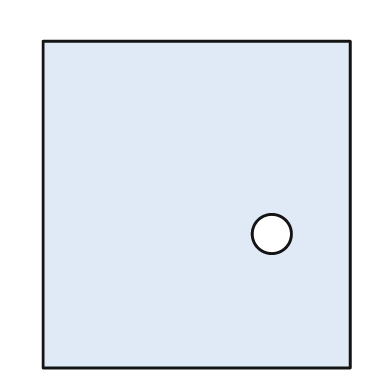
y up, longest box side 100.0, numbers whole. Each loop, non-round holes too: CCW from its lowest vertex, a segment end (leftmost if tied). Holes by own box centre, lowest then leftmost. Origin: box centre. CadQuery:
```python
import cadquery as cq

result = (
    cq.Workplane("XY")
    .moveTo(-47.0, -50.0)
    .lineTo(47.0, -50.0)
    .lineTo(47.0, 50.0)
    .lineTo(-47.0, 50.0)
    .close()
    .moveTo(23.0, -9.0)
    .circle(6.0)
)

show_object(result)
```